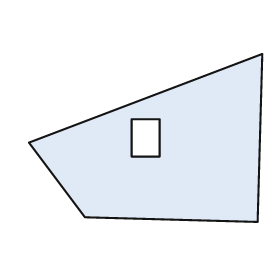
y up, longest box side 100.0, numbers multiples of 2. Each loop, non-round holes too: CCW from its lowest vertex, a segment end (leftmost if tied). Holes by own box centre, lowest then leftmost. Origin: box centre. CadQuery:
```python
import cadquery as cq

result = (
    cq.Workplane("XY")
    .moveTo(48.0, -36.0)
    .lineTo(50.0, 36.0)
    .lineTo(-50.0, -2.0)
    .lineTo(-26.0, -34.0)
    .close()
    .moveTo(-6.0, -8.0)
    .lineTo(6.0, -8.0)
    .lineTo(6.0, 8.0)
    .lineTo(-6.0, 8.0)
    .close()
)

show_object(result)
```